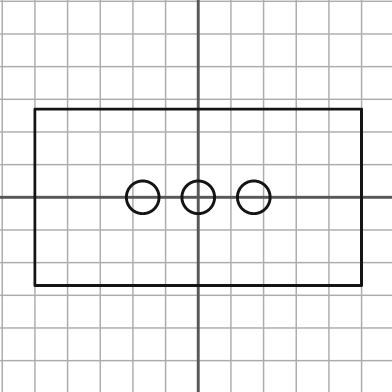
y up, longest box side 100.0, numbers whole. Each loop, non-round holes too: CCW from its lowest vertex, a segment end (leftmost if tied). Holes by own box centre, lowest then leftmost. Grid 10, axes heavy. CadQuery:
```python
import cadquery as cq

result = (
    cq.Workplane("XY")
    .moveTo(-50.0, -27.0)
    .lineTo(50.0, -27.0)
    .lineTo(50.0, 27.0)
    .lineTo(-50.0, 27.0)
    .close()
    .moveTo(-17.0, 0.0)
    .circle(5.0)
    .moveTo(0.0, 0.0)
    .circle(5.0)
    .moveTo(17.0, 0.0)
    .circle(5.0)
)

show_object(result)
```